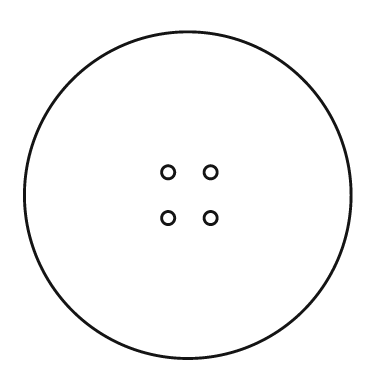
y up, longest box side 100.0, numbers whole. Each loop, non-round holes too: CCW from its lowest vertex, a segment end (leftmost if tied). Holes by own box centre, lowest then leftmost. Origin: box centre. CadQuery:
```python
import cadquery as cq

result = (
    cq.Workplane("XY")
    .moveTo(0.0, 0.0)
    .circle(50.0)
    .moveTo(-6.0, -7.0)
    .circle(2.0)
    .moveTo(7.0, -7.0)
    .circle(2.0)
    .moveTo(-6.0, 7.0)
    .circle(2.0)
    .moveTo(7.0, 7.0)
    .circle(2.0)
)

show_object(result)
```